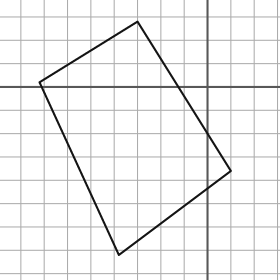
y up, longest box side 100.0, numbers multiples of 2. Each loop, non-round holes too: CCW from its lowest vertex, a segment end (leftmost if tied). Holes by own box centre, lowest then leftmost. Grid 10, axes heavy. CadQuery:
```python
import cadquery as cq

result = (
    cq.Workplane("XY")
    .moveTo(-38.0, -72.0)
    .lineTo(10.0, -36.0)
    .lineTo(-30.0, 28.0)
    .lineTo(-72.0, 2.0)
    .close()
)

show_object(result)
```